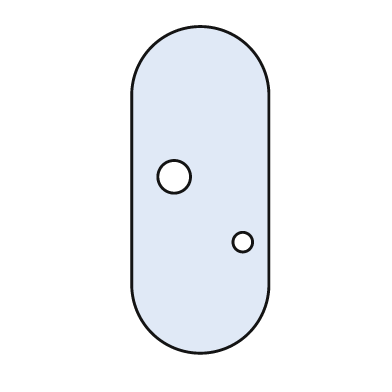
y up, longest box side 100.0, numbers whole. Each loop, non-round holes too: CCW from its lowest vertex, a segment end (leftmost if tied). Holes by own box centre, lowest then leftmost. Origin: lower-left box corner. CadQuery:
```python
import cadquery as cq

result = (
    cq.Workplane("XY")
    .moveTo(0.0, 21.0)
    .threePointArc((21.0, 0.0), (42.0, 21.0))
    .lineTo(42.0, 79.0)
    .threePointArc((21.0, 100.0), (0.0, 79.0))
    .close()
    .moveTo(34.0, 34.0)
    .circle(3.0)
    .moveTo(13.0, 54.0)
    .circle(5.0)
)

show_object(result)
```